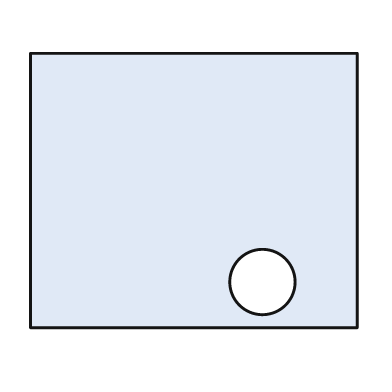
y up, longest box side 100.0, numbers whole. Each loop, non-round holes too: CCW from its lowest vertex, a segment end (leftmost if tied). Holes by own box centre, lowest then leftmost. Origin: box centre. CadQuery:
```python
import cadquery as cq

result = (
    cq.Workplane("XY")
    .moveTo(-50.0, -42.0)
    .lineTo(50.0, -42.0)
    .lineTo(50.0, 42.0)
    .lineTo(-50.0, 42.0)
    .close()
    .moveTo(21.0, -28.0)
    .circle(10.0)
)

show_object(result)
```